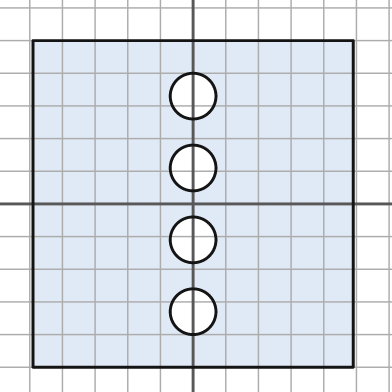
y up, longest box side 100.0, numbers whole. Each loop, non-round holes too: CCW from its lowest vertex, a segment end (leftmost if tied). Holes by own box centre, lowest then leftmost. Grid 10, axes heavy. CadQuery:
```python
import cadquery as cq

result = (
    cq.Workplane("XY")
    .moveTo(-49.0, -50.0)
    .lineTo(49.0, -50.0)
    .lineTo(49.0, 50.0)
    .lineTo(-49.0, 50.0)
    .close()
    .moveTo(0.0, -33.0)
    .circle(7.0)
    .moveTo(0.0, -11.0)
    .circle(7.0)
    .moveTo(0.0, 11.0)
    .circle(7.0)
    .moveTo(0.0, 33.0)
    .circle(7.0)
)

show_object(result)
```